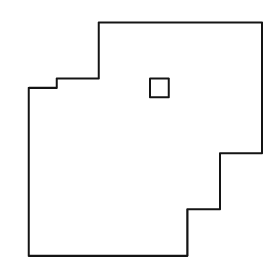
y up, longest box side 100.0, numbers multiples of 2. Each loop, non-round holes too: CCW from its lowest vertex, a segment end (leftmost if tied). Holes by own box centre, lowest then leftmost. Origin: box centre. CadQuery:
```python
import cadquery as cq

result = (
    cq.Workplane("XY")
    .moveTo(-50.0, -50.0)
    .lineTo(18.0, -50.0)
    .lineTo(18.0, -30.0)
    .lineTo(32.0, -30.0)
    .lineTo(32.0, -6.0)
    .lineTo(50.0, -6.0)
    .lineTo(50.0, 50.0)
    .lineTo(-20.0, 50.0)
    .lineTo(-20.0, 26.0)
    .lineTo(-38.0, 26.0)
    .lineTo(-38.0, 22.0)
    .lineTo(-50.0, 22.0)
    .close()
    .moveTo(2.0, 18.0)
    .lineTo(10.0, 18.0)
    .lineTo(10.0, 26.0)
    .lineTo(2.0, 26.0)
    .close()
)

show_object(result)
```